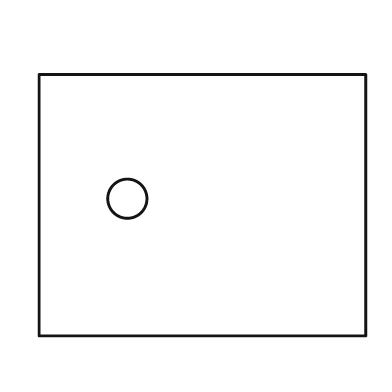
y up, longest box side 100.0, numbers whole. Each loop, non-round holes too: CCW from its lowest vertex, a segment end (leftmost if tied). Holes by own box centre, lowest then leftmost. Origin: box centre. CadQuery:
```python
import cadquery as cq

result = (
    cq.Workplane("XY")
    .moveTo(-50.0, -40.0)
    .lineTo(50.0, -40.0)
    .lineTo(50.0, 40.0)
    .lineTo(-50.0, 40.0)
    .close()
    .moveTo(-23.0, 2.0)
    .circle(6.0)
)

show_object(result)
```